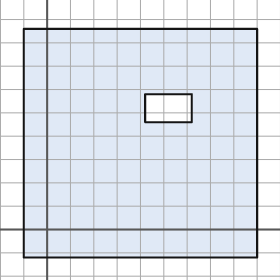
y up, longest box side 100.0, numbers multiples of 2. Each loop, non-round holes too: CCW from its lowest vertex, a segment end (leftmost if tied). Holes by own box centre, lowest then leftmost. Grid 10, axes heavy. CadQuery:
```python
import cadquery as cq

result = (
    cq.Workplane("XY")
    .moveTo(-10.0, -12.0)
    .lineTo(90.0, -12.0)
    .lineTo(90.0, 86.0)
    .lineTo(-10.0, 86.0)
    .close()
    .moveTo(42.0, 46.0)
    .lineTo(62.0, 46.0)
    .lineTo(62.0, 58.0)
    .lineTo(42.0, 58.0)
    .close()
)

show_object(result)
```